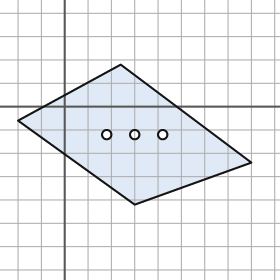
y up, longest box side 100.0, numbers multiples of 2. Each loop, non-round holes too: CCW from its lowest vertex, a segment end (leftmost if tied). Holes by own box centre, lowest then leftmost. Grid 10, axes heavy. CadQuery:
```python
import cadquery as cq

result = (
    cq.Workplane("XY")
    .moveTo(30.0, -42.0)
    .lineTo(80.0, -24.0)
    .lineTo(24.0, 18.0)
    .lineTo(-20.0, -6.0)
    .close()
    .moveTo(18.0, -12.0)
    .circle(2.0)
    .moveTo(30.0, -12.0)
    .circle(2.0)
    .moveTo(42.0, -12.0)
    .circle(2.0)
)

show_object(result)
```